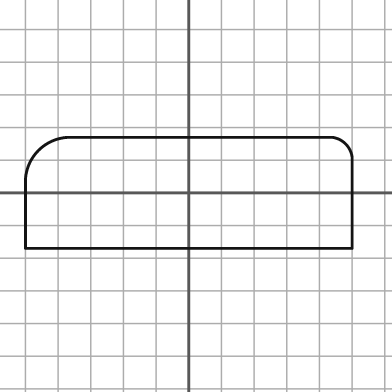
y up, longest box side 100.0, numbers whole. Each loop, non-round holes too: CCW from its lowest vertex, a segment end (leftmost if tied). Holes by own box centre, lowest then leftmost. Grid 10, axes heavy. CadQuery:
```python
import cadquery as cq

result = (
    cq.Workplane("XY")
    .moveTo(-50.0, -17.0)
    .lineTo(50.0, -17.0)
    .lineTo(50.0, 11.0)
    .threePointArc((48.0, 15.0), (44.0, 17.0))
    .lineTo(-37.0, 17.0)
    .threePointArc((-46.0, 13.0), (-50.0, 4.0))
    .close()
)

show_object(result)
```